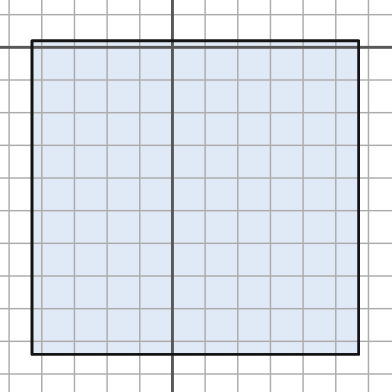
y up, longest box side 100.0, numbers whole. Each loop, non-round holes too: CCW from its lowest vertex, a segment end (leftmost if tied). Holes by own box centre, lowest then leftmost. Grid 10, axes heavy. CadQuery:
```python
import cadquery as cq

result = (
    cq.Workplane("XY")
    .moveTo(-43.0, -94.0)
    .lineTo(57.0, -94.0)
    .lineTo(57.0, 2.0)
    .lineTo(-43.0, 2.0)
    .close()
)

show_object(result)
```